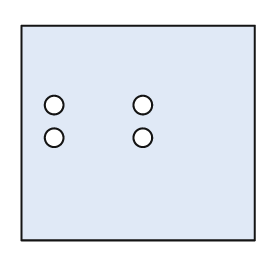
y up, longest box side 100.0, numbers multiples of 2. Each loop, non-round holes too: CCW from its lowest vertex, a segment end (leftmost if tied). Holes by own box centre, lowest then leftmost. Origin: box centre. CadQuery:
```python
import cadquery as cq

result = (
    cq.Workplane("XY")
    .moveTo(-50.0, -46.0)
    .lineTo(50.0, -46.0)
    .lineTo(50.0, 46.0)
    .lineTo(-50.0, 46.0)
    .close()
    .moveTo(-36.0, -2.0)
    .circle(4.0)
    .moveTo(2.0, -2.0)
    .circle(4.0)
    .moveTo(-36.0, 12.0)
    .circle(4.0)
    .moveTo(2.0, 12.0)
    .circle(4.0)
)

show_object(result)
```